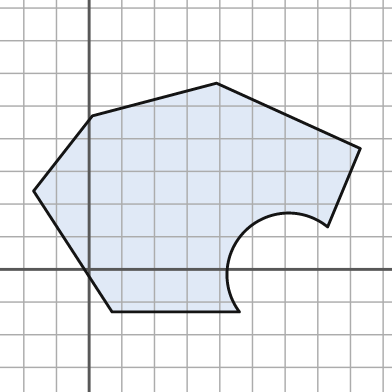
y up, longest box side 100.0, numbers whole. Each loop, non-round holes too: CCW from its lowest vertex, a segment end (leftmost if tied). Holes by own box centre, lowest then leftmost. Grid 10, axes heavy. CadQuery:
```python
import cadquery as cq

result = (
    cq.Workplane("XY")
    .moveTo(7.0, -13.0)
    .lineTo(46.0, -13.0)
    .threePointArc((48.0, 12.0), (73.0, 13.0))
    .lineTo(83.0, 37.0)
    .lineTo(39.0, 57.0)
    .lineTo(1.0, 47.0)
    .lineTo(-17.0, 24.0)
    .close()
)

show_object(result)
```